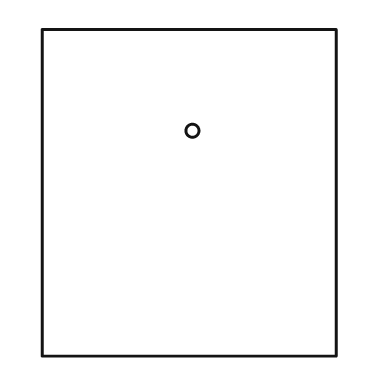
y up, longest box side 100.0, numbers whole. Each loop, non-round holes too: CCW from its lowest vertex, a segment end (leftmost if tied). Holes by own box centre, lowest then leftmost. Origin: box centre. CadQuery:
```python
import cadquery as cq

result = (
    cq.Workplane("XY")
    .moveTo(-45.0, -50.0)
    .lineTo(45.0, -50.0)
    .lineTo(45.0, 50.0)
    .lineTo(-45.0, 50.0)
    .close()
    .moveTo(1.0, 19.0)
    .circle(2.0)
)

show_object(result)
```